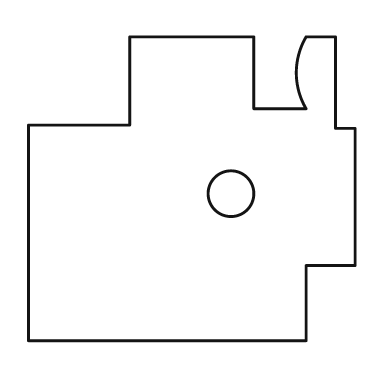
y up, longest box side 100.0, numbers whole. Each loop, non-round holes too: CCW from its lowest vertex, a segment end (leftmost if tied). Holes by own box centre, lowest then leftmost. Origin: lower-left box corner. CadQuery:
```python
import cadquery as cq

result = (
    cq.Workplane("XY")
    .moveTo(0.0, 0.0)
    .lineTo(85.0, 0.0)
    .lineTo(85.0, 23.0)
    .lineTo(100.0, 23.0)
    .lineTo(100.0, 65.0)
    .lineTo(94.0, 65.0)
    .lineTo(94.0, 93.0)
    .lineTo(85.0, 93.0)
    .threePointArc((82.0, 82.0), (85.0, 71.0))
    .lineTo(69.0, 71.0)
    .lineTo(69.0, 93.0)
    .lineTo(31.0, 93.0)
    .lineTo(31.0, 66.0)
    .lineTo(0.0, 66.0)
    .close()
    .moveTo(62.0, 45.0)
    .circle(7.0)
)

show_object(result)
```